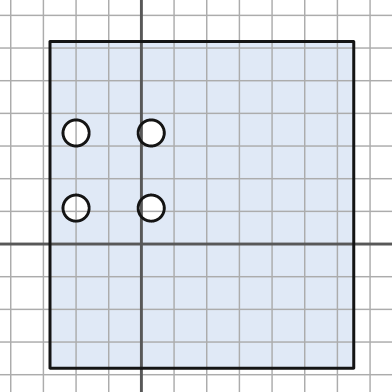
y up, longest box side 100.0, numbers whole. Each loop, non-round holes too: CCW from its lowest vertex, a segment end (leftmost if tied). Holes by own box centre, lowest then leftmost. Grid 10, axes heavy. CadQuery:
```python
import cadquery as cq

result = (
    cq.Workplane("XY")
    .moveTo(-28.0, -38.0)
    .lineTo(65.0, -38.0)
    .lineTo(65.0, 62.0)
    .lineTo(-28.0, 62.0)
    .close()
    .moveTo(-20.0, 11.0)
    .circle(4.0)
    .moveTo(3.0, 11.0)
    .circle(4.0)
    .moveTo(-20.0, 34.0)
    .circle(4.0)
    .moveTo(3.0, 34.0)
    .circle(4.0)
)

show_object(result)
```